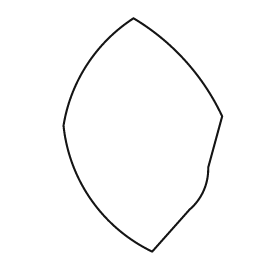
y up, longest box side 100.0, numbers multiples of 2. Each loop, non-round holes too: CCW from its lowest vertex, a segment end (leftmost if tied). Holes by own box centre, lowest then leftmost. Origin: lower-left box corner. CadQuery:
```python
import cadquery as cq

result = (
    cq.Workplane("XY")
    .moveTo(38.0, 0.0)
    .lineTo(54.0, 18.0)
    .threePointArc((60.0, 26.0), (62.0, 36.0))
    .lineTo(68.0, 58.0)
    .threePointArc((52.0, 82.0), (30.0, 100.0))
    .threePointArc((10.0, 80.0), (0.0, 54.0))
    .threePointArc((12.0, 22.0), (38.0, 0.0))
    .close()
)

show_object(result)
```